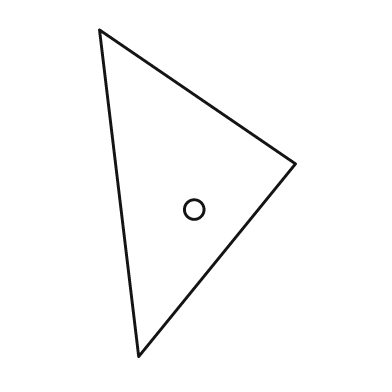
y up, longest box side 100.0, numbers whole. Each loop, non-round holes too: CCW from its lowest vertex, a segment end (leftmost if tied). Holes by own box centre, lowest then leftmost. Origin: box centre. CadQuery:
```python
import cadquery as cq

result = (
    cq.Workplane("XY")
    .moveTo(-18.0, -50.0)
    .lineTo(30.0, 9.0)
    .lineTo(-30.0, 50.0)
    .close()
    .moveTo(-1.0, -5.0)
    .circle(3.0)
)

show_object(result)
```